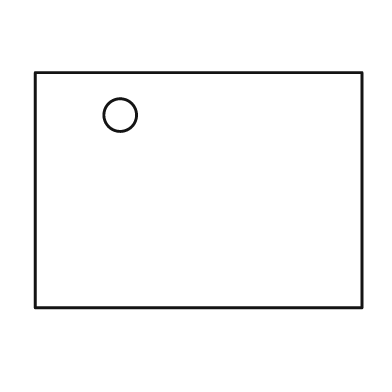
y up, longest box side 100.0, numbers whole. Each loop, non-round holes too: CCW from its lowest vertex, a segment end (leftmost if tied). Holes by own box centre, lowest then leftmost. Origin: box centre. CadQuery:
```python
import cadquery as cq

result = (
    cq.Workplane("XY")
    .moveTo(-50.0, -36.0)
    .lineTo(50.0, -36.0)
    .lineTo(50.0, 36.0)
    .lineTo(-50.0, 36.0)
    .close()
    .moveTo(-24.0, 23.0)
    .circle(5.0)
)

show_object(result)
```